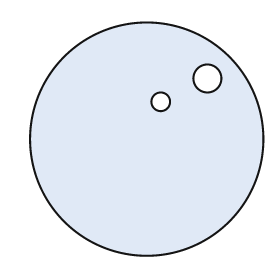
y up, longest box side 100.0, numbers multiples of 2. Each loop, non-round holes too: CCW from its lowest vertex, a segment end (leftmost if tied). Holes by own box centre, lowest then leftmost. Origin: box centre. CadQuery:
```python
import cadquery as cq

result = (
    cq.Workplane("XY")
    .moveTo(0.0, 0.0)
    .circle(50.0)
    .moveTo(6.0, 16.0)
    .circle(4.0)
    .moveTo(26.0, 26.0)
    .circle(6.0)
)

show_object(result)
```